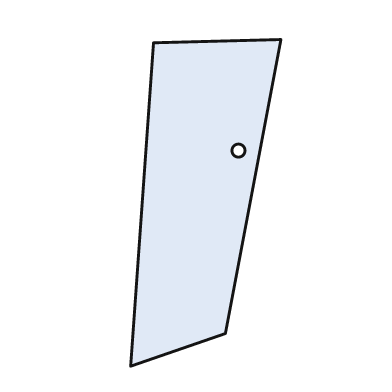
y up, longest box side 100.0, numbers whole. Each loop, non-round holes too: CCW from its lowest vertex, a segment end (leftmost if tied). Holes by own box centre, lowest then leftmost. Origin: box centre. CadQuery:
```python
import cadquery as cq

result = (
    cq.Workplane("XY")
    .moveTo(-23.0, -50.0)
    .lineTo(6.0, -40.0)
    .lineTo(23.0, 50.0)
    .lineTo(-16.0, 49.0)
    .close()
    .moveTo(10.0, 16.0)
    .circle(2.0)
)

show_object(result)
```